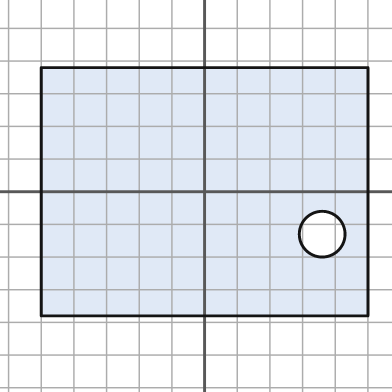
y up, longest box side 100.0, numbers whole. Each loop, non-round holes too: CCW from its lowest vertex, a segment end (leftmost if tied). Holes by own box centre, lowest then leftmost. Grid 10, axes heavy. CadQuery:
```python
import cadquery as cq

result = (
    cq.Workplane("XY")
    .moveTo(-50.0, -38.0)
    .lineTo(50.0, -38.0)
    .lineTo(50.0, 38.0)
    .lineTo(-50.0, 38.0)
    .close()
    .moveTo(36.0, -13.0)
    .circle(7.0)
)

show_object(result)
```